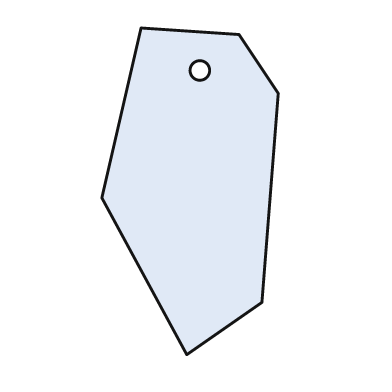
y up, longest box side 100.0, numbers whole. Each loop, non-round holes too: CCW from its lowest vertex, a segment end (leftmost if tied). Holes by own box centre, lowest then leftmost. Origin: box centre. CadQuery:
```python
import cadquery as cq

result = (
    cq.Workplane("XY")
    .moveTo(-1.0, -50.0)
    .lineTo(22.0, -34.0)
    .lineTo(27.0, 30.0)
    .lineTo(15.0, 48.0)
    .lineTo(-15.0, 50.0)
    .lineTo(-27.0, -2.0)
    .close()
    .moveTo(3.0, 37.0)
    .circle(3.0)
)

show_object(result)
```